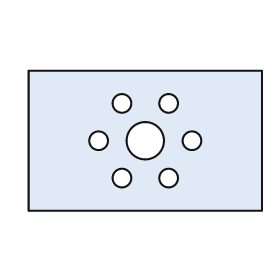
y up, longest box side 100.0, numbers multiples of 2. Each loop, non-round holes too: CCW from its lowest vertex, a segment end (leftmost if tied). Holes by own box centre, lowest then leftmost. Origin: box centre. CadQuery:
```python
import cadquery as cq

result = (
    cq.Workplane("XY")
    .moveTo(-50.0, -30.0)
    .lineTo(50.0, -30.0)
    .lineTo(50.0, 30.0)
    .lineTo(-50.0, 30.0)
    .close()
    .moveTo(-10.0, -16.0)
    .circle(4.0)
    .moveTo(10.0, -16.0)
    .circle(4.0)
    .moveTo(-20.0, 0.0)
    .circle(4.0)
    .moveTo(0.0, 0.0)
    .circle(8.0)
    .moveTo(20.0, 0.0)
    .circle(4.0)
    .moveTo(-10.0, 16.0)
    .circle(4.0)
    .moveTo(10.0, 16.0)
    .circle(4.0)
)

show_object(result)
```